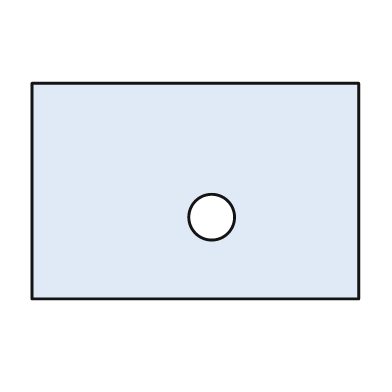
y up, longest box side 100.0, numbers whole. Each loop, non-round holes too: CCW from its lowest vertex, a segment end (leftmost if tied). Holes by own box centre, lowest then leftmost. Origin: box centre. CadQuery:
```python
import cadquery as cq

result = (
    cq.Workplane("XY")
    .moveTo(-50.0, -33.0)
    .lineTo(50.0, -33.0)
    .lineTo(50.0, 33.0)
    .lineTo(-50.0, 33.0)
    .close()
    .moveTo(5.0, -8.0)
    .circle(7.0)
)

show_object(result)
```